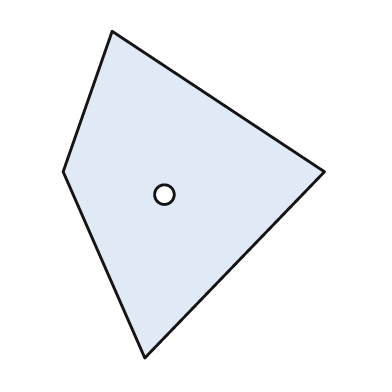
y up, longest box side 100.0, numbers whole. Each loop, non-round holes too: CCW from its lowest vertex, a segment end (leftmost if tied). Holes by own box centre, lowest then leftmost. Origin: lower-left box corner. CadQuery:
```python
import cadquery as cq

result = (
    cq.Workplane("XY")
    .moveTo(25.0, 0.0)
    .lineTo(80.0, 57.0)
    .lineTo(15.0, 100.0)
    .lineTo(0.0, 57.0)
    .close()
    .moveTo(31.0, 50.0)
    .circle(3.0)
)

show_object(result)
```